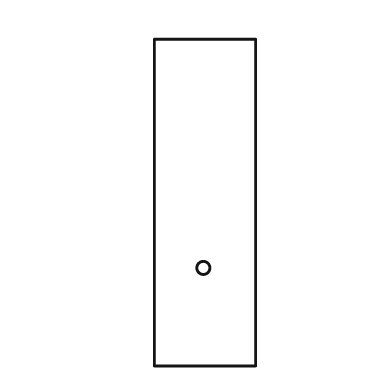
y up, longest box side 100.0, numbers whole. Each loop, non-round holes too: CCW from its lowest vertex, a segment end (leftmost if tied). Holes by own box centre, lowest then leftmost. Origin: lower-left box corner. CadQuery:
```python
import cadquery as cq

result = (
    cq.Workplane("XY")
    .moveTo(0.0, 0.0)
    .lineTo(31.0, 0.0)
    .lineTo(31.0, 100.0)
    .lineTo(0.0, 100.0)
    .close()
    .moveTo(15.0, 30.0)
    .circle(2.0)
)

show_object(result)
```